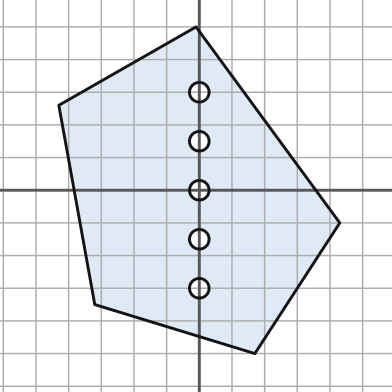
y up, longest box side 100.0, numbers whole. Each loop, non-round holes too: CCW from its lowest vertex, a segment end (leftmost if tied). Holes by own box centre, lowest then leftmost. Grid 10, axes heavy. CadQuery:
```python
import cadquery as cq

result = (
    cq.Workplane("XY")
    .moveTo(17.0, -50.0)
    .lineTo(43.0, -10.0)
    .lineTo(-1.0, 50.0)
    .lineTo(-43.0, 26.0)
    .lineTo(-32.0, -35.0)
    .close()
    .moveTo(0.0, -30.0)
    .circle(3.0)
    .moveTo(0.0, -15.0)
    .circle(3.0)
    .moveTo(0.0, 0.0)
    .circle(3.0)
    .moveTo(0.0, 15.0)
    .circle(3.0)
    .moveTo(0.0, 30.0)
    .circle(3.0)
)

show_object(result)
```